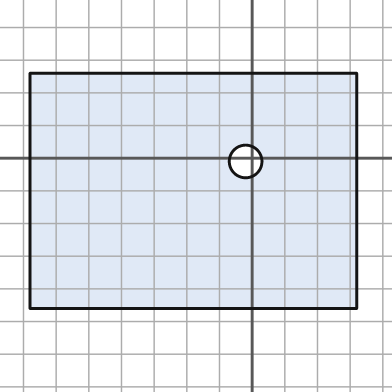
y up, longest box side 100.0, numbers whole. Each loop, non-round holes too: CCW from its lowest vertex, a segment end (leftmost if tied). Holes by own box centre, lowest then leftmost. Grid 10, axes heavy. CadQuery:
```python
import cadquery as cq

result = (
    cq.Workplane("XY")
    .moveTo(-68.0, -46.0)
    .lineTo(32.0, -46.0)
    .lineTo(32.0, 26.0)
    .lineTo(-68.0, 26.0)
    .close()
    .moveTo(-2.0, -1.0)
    .circle(5.0)
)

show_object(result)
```